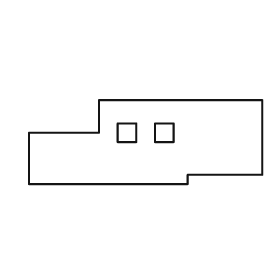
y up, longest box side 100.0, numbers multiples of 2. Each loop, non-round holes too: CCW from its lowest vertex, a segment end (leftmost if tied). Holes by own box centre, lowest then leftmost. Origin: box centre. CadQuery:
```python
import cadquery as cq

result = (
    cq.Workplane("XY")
    .moveTo(-50.0, -18.0)
    .lineTo(18.0, -18.0)
    .lineTo(18.0, -14.0)
    .lineTo(50.0, -14.0)
    .lineTo(50.0, 18.0)
    .lineTo(-20.0, 18.0)
    .lineTo(-20.0, 4.0)
    .lineTo(-50.0, 4.0)
    .close()
    .moveTo(-12.0, 0.0)
    .lineTo(-4.0, 0.0)
    .lineTo(-4.0, 8.0)
    .lineTo(-12.0, 8.0)
    .close()
    .moveTo(4.0, 0.0)
    .lineTo(12.0, 0.0)
    .lineTo(12.0, 8.0)
    .lineTo(4.0, 8.0)
    .close()
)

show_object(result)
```